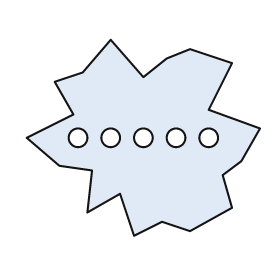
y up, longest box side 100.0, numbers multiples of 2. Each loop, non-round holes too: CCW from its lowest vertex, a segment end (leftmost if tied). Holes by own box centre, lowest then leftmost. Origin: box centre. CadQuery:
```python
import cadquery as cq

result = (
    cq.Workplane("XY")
    .moveTo(-4.0, -42.0)
    .lineTo(8.0, -36.0)
    .lineTo(20.0, -40.0)
    .lineTo(38.0, -30.0)
    .lineTo(34.0, -16.0)
    .lineTo(42.0, -10.0)
    .lineTo(50.0, 4.0)
    .lineTo(28.0, 12.0)
    .lineTo(38.0, 32.0)
    .lineTo(20.0, 38.0)
    .lineTo(10.0, 34.0)
    .lineTo(0.0, 26.0)
    .lineTo(-14.0, 42.0)
    .lineTo(-26.0, 28.0)
    .lineTo(-38.0, 24.0)
    .lineTo(-30.0, 10.0)
    .lineTo(-50.0, 0.0)
    .lineTo(-36.0, -12.0)
    .lineTo(-22.0, -14.0)
    .lineTo(-24.0, -32.0)
    .lineTo(-10.0, -24.0)
    .close()
    .moveTo(-28.0, 0.0)
    .circle(4.0)
    .moveTo(-14.0, 0.0)
    .circle(4.0)
    .moveTo(0.0, 0.0)
    .circle(4.0)
    .moveTo(14.0, 0.0)
    .circle(4.0)
    .moveTo(28.0, 0.0)
    .circle(4.0)
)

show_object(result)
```